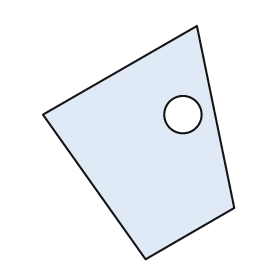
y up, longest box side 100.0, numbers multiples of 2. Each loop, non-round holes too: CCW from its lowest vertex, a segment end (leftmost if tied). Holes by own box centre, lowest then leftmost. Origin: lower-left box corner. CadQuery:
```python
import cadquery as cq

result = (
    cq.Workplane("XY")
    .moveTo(44.0, 0.0)
    .lineTo(82.0, 22.0)
    .lineTo(66.0, 100.0)
    .lineTo(0.0, 62.0)
    .close()
    .moveTo(60.0, 62.0)
    .circle(8.0)
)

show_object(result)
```